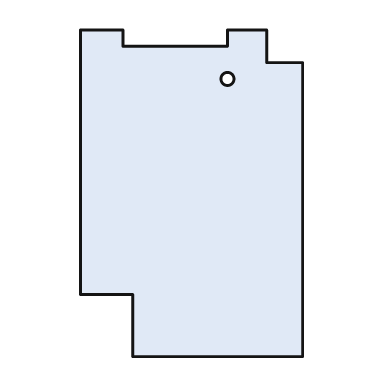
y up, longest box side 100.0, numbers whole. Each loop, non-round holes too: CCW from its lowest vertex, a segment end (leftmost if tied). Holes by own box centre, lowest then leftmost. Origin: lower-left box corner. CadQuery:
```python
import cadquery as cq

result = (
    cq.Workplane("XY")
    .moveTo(16.0, 0.0)
    .lineTo(68.0, 0.0)
    .lineTo(68.0, 90.0)
    .lineTo(57.0, 90.0)
    .lineTo(57.0, 100.0)
    .lineTo(45.0, 100.0)
    .lineTo(45.0, 95.0)
    .lineTo(13.0, 95.0)
    .lineTo(13.0, 100.0)
    .lineTo(0.0, 100.0)
    .lineTo(0.0, 19.0)
    .lineTo(16.0, 19.0)
    .close()
    .moveTo(45.0, 85.0)
    .circle(2.0)
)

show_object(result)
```